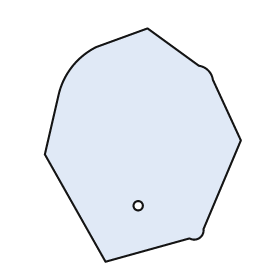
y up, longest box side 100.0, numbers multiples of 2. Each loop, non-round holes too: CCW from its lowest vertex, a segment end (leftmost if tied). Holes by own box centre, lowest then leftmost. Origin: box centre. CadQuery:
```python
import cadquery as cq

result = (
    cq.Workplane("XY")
    .moveTo(-16.0, -50.0)
    .lineTo(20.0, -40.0)
    .threePointArc((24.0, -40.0), (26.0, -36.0))
    .lineTo(42.0, 2.0)
    .lineTo(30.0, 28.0)
    .threePointArc((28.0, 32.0), (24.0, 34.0))
    .lineTo(2.0, 50.0)
    .lineTo(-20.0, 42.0)
    .threePointArc((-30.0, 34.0), (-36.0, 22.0))
    .lineTo(-42.0, -4.0)
    .close()
    .moveTo(-2.0, -26.0)
    .circle(2.0)
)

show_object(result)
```